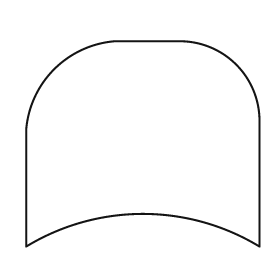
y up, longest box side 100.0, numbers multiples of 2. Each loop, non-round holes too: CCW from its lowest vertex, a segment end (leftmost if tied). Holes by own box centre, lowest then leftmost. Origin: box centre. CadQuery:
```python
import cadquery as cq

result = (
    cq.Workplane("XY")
    .moveTo(-50.0, -44.0)
    .threePointArc((0.0, -30.0), (50.0, -44.0))
    .lineTo(50.0, 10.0)
    .threePointArc((40.0, 34.0), (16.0, 44.0))
    .lineTo(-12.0, 44.0)
    .threePointArc((-38.0, 32.0), (-50.0, 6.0))
    .close()
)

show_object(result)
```